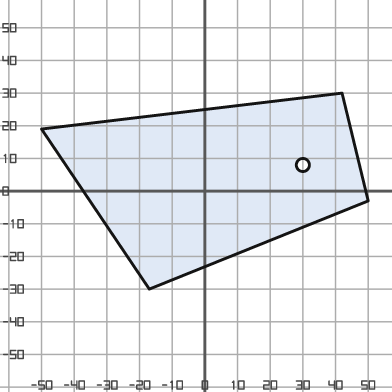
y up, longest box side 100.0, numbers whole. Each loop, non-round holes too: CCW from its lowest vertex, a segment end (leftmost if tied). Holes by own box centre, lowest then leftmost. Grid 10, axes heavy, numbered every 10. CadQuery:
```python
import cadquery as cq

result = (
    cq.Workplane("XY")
    .moveTo(-17.0, -30.0)
    .lineTo(50.0, -3.0)
    .lineTo(42.0, 30.0)
    .lineTo(-50.0, 19.0)
    .close()
    .moveTo(30.0, 8.0)
    .circle(2.0)
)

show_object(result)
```